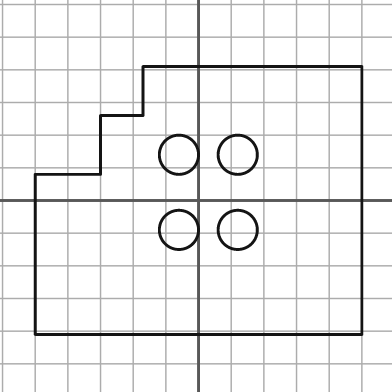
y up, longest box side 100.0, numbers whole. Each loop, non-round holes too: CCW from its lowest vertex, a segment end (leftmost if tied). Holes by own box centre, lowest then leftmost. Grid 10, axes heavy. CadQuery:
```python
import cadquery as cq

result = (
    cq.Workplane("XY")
    .moveTo(-50.0, -41.0)
    .lineTo(50.0, -41.0)
    .lineTo(50.0, 41.0)
    .lineTo(-17.0, 41.0)
    .lineTo(-17.0, 26.0)
    .lineTo(-30.0, 26.0)
    .lineTo(-30.0, 8.0)
    .lineTo(-50.0, 8.0)
    .close()
    .moveTo(-6.0, -9.0)
    .circle(6.0)
    .moveTo(12.0, -9.0)
    .circle(6.0)
    .moveTo(-6.0, 14.0)
    .circle(6.0)
    .moveTo(12.0, 14.0)
    .circle(6.0)
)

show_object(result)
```